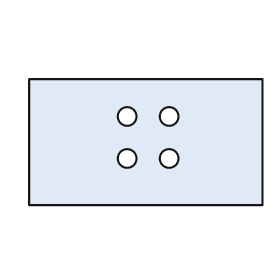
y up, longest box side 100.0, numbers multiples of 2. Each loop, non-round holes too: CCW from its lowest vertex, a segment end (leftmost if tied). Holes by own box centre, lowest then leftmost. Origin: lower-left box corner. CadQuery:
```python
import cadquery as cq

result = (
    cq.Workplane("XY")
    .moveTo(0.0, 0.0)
    .lineTo(100.0, 0.0)
    .lineTo(100.0, 54.0)
    .lineTo(0.0, 54.0)
    .close()
    .moveTo(42.0, 20.0)
    .circle(4.0)
    .moveTo(60.0, 20.0)
    .circle(4.0)
    .moveTo(42.0, 38.0)
    .circle(4.0)
    .moveTo(60.0, 38.0)
    .circle(4.0)
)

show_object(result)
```